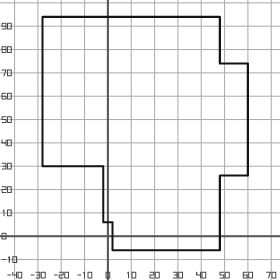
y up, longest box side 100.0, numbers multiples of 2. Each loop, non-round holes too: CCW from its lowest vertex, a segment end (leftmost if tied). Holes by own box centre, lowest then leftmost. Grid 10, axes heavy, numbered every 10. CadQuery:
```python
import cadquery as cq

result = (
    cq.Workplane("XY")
    .moveTo(2.0, -6.0)
    .lineTo(48.0, -6.0)
    .lineTo(48.0, 26.0)
    .lineTo(60.0, 26.0)
    .lineTo(60.0, 74.0)
    .lineTo(48.0, 74.0)
    .lineTo(48.0, 94.0)
    .lineTo(-28.0, 94.0)
    .lineTo(-28.0, 30.0)
    .lineTo(-2.0, 30.0)
    .lineTo(-2.0, 6.0)
    .lineTo(2.0, 6.0)
    .close()
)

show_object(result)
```